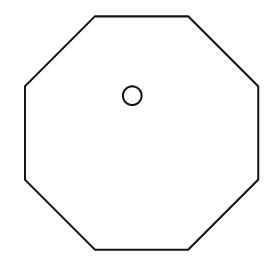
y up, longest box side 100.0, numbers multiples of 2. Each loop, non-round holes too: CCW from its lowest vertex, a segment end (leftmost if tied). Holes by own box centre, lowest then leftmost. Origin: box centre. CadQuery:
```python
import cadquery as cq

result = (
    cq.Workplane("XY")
    .moveTo(-20.0, -50.0)
    .lineTo(20.0, -50.0)
    .lineTo(50.0, -20.0)
    .lineTo(50.0, 20.0)
    .lineTo(20.0, 50.0)
    .lineTo(-20.0, 50.0)
    .lineTo(-50.0, 20.0)
    .lineTo(-50.0, -20.0)
    .close()
    .moveTo(-4.0, 16.0)
    .circle(4.0)
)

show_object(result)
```